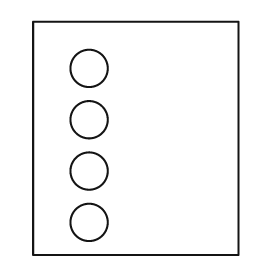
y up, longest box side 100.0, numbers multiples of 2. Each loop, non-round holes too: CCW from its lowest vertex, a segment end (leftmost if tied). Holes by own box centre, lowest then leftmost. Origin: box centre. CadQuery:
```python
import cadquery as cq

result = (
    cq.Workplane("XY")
    .moveTo(-44.0, -50.0)
    .lineTo(44.0, -50.0)
    .lineTo(44.0, 50.0)
    .lineTo(-44.0, 50.0)
    .close()
    .moveTo(-20.0, -36.0)
    .circle(8.0)
    .moveTo(-20.0, -14.0)
    .circle(8.0)
    .moveTo(-20.0, 8.0)
    .circle(8.0)
    .moveTo(-20.0, 30.0)
    .circle(8.0)
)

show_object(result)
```